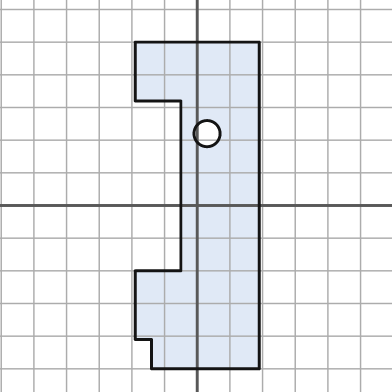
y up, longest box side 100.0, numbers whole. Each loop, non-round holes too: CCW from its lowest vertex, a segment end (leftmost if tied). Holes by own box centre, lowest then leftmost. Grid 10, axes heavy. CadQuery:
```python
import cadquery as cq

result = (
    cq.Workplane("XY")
    .moveTo(-14.0, -50.0)
    .lineTo(19.0, -50.0)
    .lineTo(19.0, 50.0)
    .lineTo(-19.0, 50.0)
    .lineTo(-19.0, 32.0)
    .lineTo(-5.0, 32.0)
    .lineTo(-5.0, -20.0)
    .lineTo(-19.0, -20.0)
    .lineTo(-19.0, -41.0)
    .lineTo(-14.0, -41.0)
    .close()
    .moveTo(3.0, 22.0)
    .circle(4.0)
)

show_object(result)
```